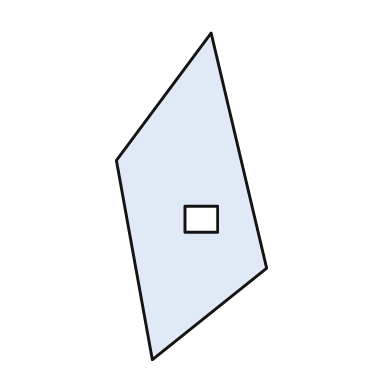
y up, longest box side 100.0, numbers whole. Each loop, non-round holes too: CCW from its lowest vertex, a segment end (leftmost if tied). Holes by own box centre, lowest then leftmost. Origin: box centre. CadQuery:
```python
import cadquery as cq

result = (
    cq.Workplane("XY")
    .moveTo(-12.0, -50.0)
    .lineTo(23.0, -22.0)
    .lineTo(6.0, 50.0)
    .lineTo(-23.0, 11.0)
    .close()
    .moveTo(-2.0, -11.0)
    .lineTo(8.0, -11.0)
    .lineTo(8.0, -3.0)
    .lineTo(-2.0, -3.0)
    .close()
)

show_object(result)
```